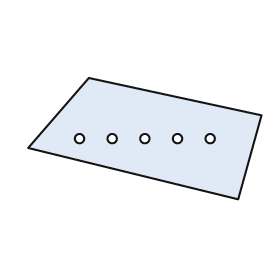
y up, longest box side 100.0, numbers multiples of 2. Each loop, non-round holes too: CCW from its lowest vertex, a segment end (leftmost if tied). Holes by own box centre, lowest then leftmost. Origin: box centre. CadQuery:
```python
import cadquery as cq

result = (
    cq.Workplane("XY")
    .moveTo(40.0, -26.0)
    .lineTo(50.0, 10.0)
    .lineTo(-24.0, 26.0)
    .lineTo(-50.0, -4.0)
    .close()
    .moveTo(-28.0, 0.0)
    .circle(2.0)
    .moveTo(-14.0, 0.0)
    .circle(2.0)
    .moveTo(0.0, 0.0)
    .circle(2.0)
    .moveTo(14.0, 0.0)
    .circle(2.0)
    .moveTo(28.0, 0.0)
    .circle(2.0)
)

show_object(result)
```